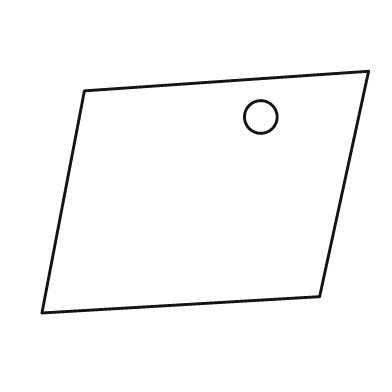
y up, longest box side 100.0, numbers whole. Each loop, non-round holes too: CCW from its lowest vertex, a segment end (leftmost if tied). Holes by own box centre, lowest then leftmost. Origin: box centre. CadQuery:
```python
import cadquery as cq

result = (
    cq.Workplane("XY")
    .moveTo(-50.0, -37.0)
    .lineTo(35.0, -32.0)
    .lineTo(50.0, 37.0)
    .lineTo(-37.0, 31.0)
    .close()
    .moveTo(17.0, 23.0)
    .circle(5.0)
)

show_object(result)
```